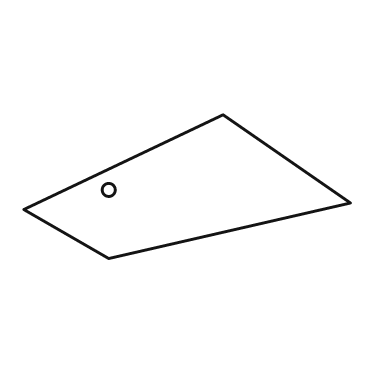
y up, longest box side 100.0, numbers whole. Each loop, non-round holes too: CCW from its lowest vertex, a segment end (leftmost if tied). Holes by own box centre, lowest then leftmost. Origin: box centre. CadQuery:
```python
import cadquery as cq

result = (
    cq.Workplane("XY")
    .moveTo(-24.0, -22.0)
    .lineTo(50.0, -5.0)
    .lineTo(11.0, 22.0)
    .lineTo(-50.0, -7.0)
    .close()
    .moveTo(-24.0, -1.0)
    .circle(2.0)
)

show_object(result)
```